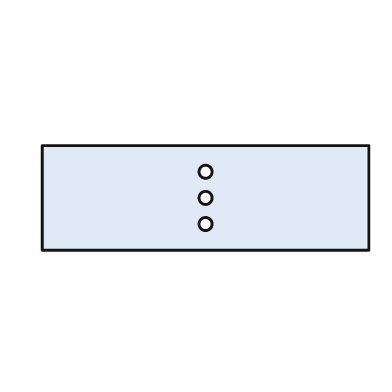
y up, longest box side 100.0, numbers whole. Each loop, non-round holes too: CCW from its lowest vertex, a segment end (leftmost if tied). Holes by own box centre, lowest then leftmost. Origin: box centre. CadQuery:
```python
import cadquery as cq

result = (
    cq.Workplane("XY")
    .moveTo(-50.0, -16.0)
    .lineTo(50.0, -16.0)
    .lineTo(50.0, 16.0)
    .lineTo(-50.0, 16.0)
    .close()
    .moveTo(0.0, -8.0)
    .circle(2.0)
    .moveTo(0.0, 0.0)
    .circle(2.0)
    .moveTo(0.0, 8.0)
    .circle(2.0)
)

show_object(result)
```